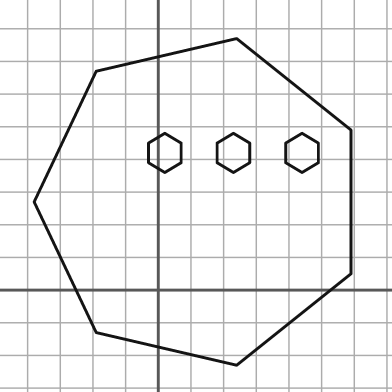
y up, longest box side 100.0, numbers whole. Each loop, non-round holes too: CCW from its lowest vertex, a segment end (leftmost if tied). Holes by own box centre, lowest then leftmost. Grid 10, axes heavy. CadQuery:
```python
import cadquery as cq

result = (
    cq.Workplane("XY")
    .moveTo(24.0, -23.0)
    .lineTo(59.0, 5.0)
    .lineTo(59.0, 49.0)
    .lineTo(24.0, 77.0)
    .lineTo(-19.0, 67.0)
    .lineTo(-38.0, 27.0)
    .lineTo(-19.0, -13.0)
    .close()
    .moveTo(2.0, 36.0)
    .lineTo(7.0, 39.0)
    .lineTo(7.0, 45.0)
    .lineTo(2.0, 48.0)
    .lineTo(-3.0, 45.0)
    .lineTo(-3.0, 39.0)
    .close()
    .moveTo(23.0, 36.0)
    .lineTo(28.0, 39.0)
    .lineTo(28.0, 45.0)
    .lineTo(23.0, 48.0)
    .lineTo(18.0, 45.0)
    .lineTo(18.0, 39.0)
    .close()
    .moveTo(44.0, 36.0)
    .lineTo(49.0, 39.0)
    .lineTo(49.0, 45.0)
    .lineTo(44.0, 48.0)
    .lineTo(39.0, 45.0)
    .lineTo(39.0, 39.0)
    .close()
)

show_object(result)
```